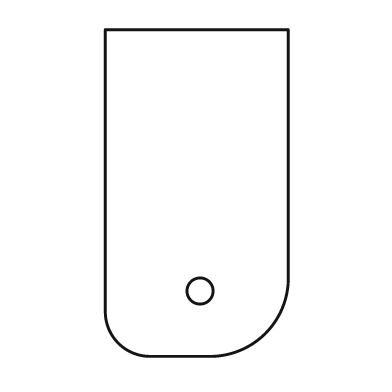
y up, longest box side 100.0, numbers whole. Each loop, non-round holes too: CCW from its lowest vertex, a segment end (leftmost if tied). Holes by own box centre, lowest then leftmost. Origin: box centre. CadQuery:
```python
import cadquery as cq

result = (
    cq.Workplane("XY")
    .moveTo(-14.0, -50.0)
    .lineTo(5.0, -50.0)
    .threePointArc((21.0, -43.0), (28.0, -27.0))
    .lineTo(28.0, 50.0)
    .lineTo(-28.0, 50.0)
    .lineTo(-28.0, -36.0)
    .threePointArc((-24.0, -46.0), (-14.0, -50.0))
    .close()
    .moveTo(1.0, -30.0)
    .circle(4.0)
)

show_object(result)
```